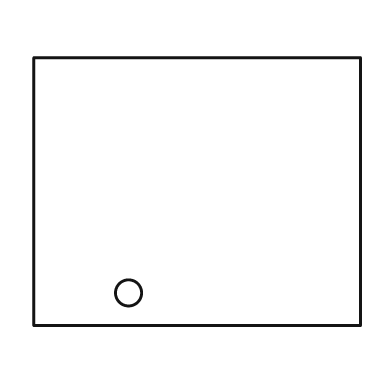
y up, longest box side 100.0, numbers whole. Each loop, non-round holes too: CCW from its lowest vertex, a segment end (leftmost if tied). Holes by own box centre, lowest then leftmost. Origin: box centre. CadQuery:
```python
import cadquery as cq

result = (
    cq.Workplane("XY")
    .moveTo(-50.0, -41.0)
    .lineTo(50.0, -41.0)
    .lineTo(50.0, 41.0)
    .lineTo(-50.0, 41.0)
    .close()
    .moveTo(-21.0, -31.0)
    .circle(4.0)
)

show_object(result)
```